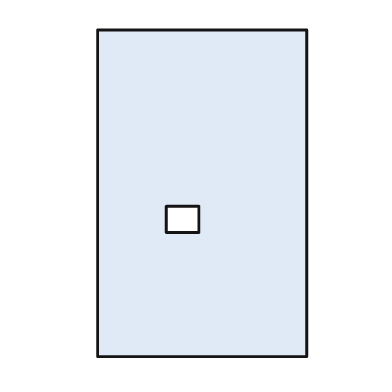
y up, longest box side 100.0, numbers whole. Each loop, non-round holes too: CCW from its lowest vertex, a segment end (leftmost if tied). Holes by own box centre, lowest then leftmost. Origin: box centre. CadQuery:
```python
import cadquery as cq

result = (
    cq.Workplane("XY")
    .moveTo(-32.0, -50.0)
    .lineTo(32.0, -50.0)
    .lineTo(32.0, 50.0)
    .lineTo(-32.0, 50.0)
    .close()
    .moveTo(-11.0, -12.0)
    .lineTo(-1.0, -12.0)
    .lineTo(-1.0, -4.0)
    .lineTo(-11.0, -4.0)
    .close()
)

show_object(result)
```